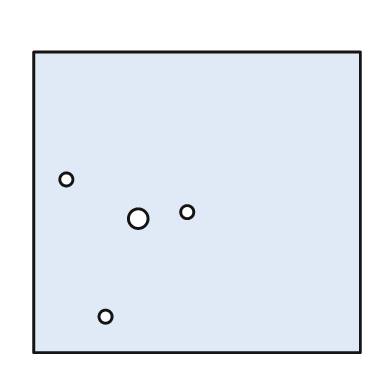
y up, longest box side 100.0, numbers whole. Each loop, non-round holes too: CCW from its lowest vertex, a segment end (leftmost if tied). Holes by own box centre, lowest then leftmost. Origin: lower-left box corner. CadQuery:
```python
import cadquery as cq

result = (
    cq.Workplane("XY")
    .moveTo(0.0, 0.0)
    .lineTo(100.0, 0.0)
    .lineTo(100.0, 92.0)
    .lineTo(0.0, 92.0)
    .close()
    .moveTo(22.0, 11.0)
    .circle(2.0)
    .moveTo(32.0, 41.0)
    .circle(3.0)
    .moveTo(47.0, 43.0)
    .circle(2.0)
    .moveTo(10.0, 53.0)
    .circle(2.0)
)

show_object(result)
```